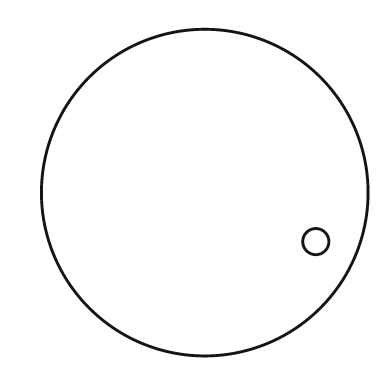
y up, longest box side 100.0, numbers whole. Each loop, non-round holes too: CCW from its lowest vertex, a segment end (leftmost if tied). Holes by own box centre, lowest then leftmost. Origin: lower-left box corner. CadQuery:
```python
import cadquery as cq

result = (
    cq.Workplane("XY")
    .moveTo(50.0, 50.0)
    .circle(50.0)
    .moveTo(84.0, 35.0)
    .circle(4.0)
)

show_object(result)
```